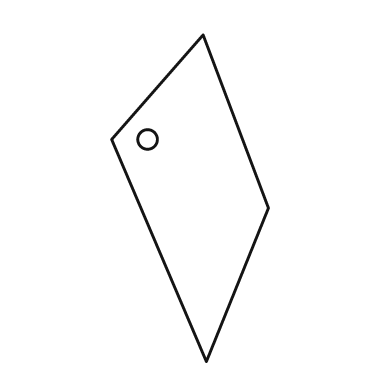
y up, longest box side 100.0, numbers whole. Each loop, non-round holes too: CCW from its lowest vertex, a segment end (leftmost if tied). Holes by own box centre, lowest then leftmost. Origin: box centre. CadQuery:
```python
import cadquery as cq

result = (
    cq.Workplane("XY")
    .moveTo(5.0, -50.0)
    .lineTo(24.0, -3.0)
    .lineTo(4.0, 50.0)
    .lineTo(-24.0, 18.0)
    .close()
    .moveTo(-13.0, 18.0)
    .circle(3.0)
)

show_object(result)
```